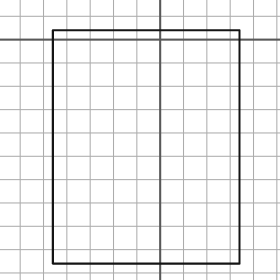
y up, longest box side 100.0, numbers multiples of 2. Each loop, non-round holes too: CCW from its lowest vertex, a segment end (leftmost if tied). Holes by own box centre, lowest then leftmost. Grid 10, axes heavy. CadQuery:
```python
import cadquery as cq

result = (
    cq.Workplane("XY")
    .moveTo(-46.0, -96.0)
    .lineTo(34.0, -96.0)
    .lineTo(34.0, 4.0)
    .lineTo(-46.0, 4.0)
    .close()
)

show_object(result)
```